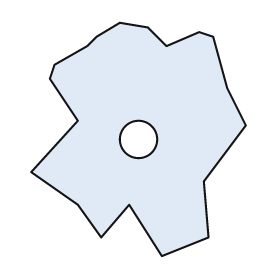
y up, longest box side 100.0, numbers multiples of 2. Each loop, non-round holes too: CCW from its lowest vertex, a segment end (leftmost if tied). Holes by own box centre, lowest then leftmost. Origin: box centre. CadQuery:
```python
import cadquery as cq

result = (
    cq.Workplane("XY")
    .moveTo(10.0, -50.0)
    .lineTo(30.0, -42.0)
    .lineTo(28.0, -18.0)
    .lineTo(46.0, 6.0)
    .lineTo(38.0, 22.0)
    .lineTo(32.0, 44.0)
    .lineTo(26.0, 46.0)
    .lineTo(12.0, 40.0)
    .lineTo(4.0, 48.0)
    .lineTo(-8.0, 50.0)
    .lineTo(-18.0, 44.0)
    .lineTo(-22.0, 40.0)
    .lineTo(-36.0, 32.0)
    .lineTo(-38.0, 26.0)
    .lineTo(-26.0, 8.0)
    .lineTo(-46.0, -14.0)
    .lineTo(-26.0, -28.0)
    .lineTo(-16.0, -42.0)
    .lineTo(-4.0, -28.0)
    .close()
    .moveTo(0.0, 0.0)
    .circle(8.0)
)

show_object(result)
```